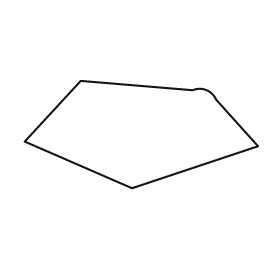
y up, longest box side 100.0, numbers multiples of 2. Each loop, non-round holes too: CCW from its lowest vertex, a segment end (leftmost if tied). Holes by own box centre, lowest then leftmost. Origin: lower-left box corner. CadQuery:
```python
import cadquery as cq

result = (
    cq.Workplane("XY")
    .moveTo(46.0, 0.0)
    .lineTo(100.0, 18.0)
    .lineTo(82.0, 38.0)
    .threePointArc((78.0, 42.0), (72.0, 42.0))
    .lineTo(24.0, 46.0)
    .lineTo(0.0, 20.0)
    .close()
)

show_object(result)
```